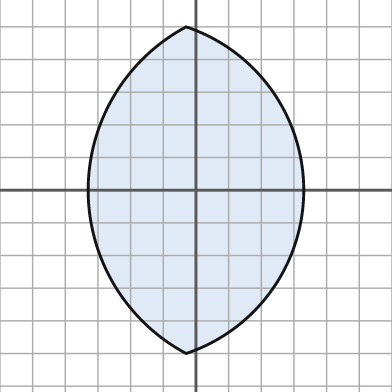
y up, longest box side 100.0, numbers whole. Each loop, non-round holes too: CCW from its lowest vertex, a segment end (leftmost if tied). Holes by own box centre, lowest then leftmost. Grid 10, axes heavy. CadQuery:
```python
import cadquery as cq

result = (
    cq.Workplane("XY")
    .moveTo(-3.0, -50.0)
    .threePointArc((33.0, 0.0), (-3.0, 50.0))
    .threePointArc((-33.0, 0.0), (-3.0, -50.0))
    .close()
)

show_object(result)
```